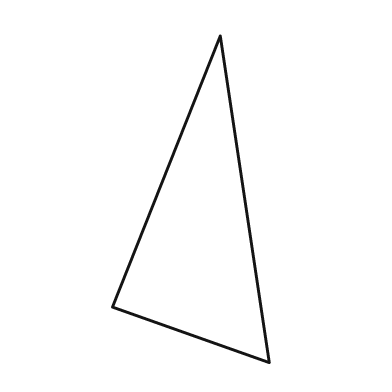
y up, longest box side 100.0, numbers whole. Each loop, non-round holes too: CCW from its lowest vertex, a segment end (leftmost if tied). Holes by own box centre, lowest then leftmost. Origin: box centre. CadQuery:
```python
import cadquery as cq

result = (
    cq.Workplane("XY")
    .moveTo(24.0, -50.0)
    .lineTo(9.0, 50.0)
    .lineTo(-24.0, -33.0)
    .close()
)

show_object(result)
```